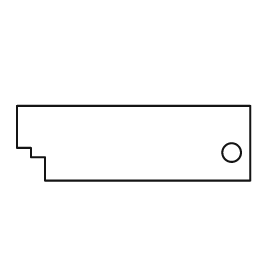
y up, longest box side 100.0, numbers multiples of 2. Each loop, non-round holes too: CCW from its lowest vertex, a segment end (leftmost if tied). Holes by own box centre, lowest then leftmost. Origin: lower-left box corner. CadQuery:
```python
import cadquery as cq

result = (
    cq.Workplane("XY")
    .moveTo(12.0, 0.0)
    .lineTo(100.0, 0.0)
    .lineTo(100.0, 32.0)
    .lineTo(0.0, 32.0)
    .lineTo(0.0, 14.0)
    .lineTo(6.0, 14.0)
    .lineTo(6.0, 10.0)
    .lineTo(12.0, 10.0)
    .close()
    .moveTo(92.0, 12.0)
    .circle(4.0)
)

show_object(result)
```